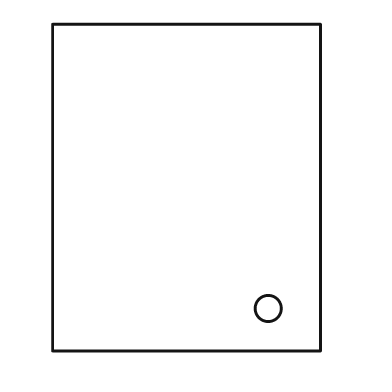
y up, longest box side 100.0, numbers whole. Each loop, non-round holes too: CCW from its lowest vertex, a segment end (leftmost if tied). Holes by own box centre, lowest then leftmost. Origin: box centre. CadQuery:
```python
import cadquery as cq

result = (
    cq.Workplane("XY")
    .moveTo(-41.0, -50.0)
    .lineTo(41.0, -50.0)
    .lineTo(41.0, 50.0)
    .lineTo(-41.0, 50.0)
    .close()
    .moveTo(25.0, -37.0)
    .circle(4.0)
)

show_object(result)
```